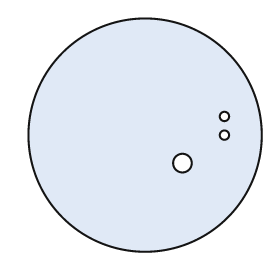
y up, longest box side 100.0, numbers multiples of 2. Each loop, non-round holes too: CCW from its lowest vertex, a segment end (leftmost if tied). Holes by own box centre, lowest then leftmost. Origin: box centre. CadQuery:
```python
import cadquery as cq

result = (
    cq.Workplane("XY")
    .moveTo(0.0, 0.0)
    .circle(50.0)
    .moveTo(16.0, -12.0)
    .circle(4.0)
    .moveTo(34.0, 0.0)
    .circle(2.0)
    .moveTo(34.0, 8.0)
    .circle(2.0)
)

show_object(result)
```